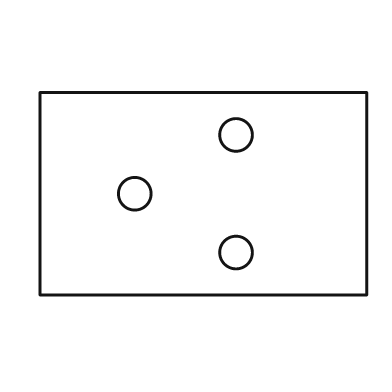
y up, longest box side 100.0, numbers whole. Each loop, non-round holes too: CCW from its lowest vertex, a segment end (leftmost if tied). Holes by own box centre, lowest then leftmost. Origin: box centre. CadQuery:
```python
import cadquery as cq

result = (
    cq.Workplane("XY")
    .moveTo(-50.0, -31.0)
    .lineTo(50.0, -31.0)
    .lineTo(50.0, 31.0)
    .lineTo(-50.0, 31.0)
    .close()
    .moveTo(10.0, -18.0)
    .circle(5.0)
    .moveTo(-21.0, 0.0)
    .circle(5.0)
    .moveTo(10.0, 18.0)
    .circle(5.0)
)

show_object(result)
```